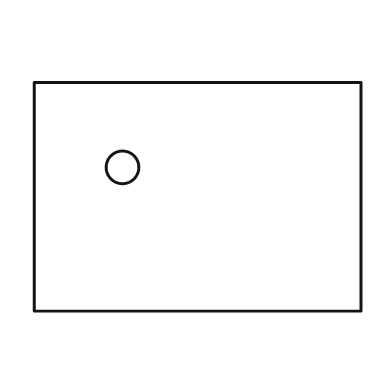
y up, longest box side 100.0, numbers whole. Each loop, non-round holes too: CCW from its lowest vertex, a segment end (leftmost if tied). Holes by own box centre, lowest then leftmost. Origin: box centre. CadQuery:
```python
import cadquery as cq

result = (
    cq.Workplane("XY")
    .moveTo(-50.0, -35.0)
    .lineTo(50.0, -35.0)
    .lineTo(50.0, 35.0)
    .lineTo(-50.0, 35.0)
    .close()
    .moveTo(-23.0, 9.0)
    .circle(5.0)
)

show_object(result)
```